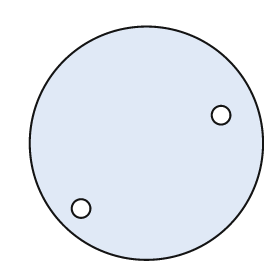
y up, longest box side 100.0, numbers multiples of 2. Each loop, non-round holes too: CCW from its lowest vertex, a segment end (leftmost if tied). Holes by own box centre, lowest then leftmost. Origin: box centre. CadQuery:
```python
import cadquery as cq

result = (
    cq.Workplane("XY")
    .moveTo(0.0, 0.0)
    .circle(50.0)
    .moveTo(-28.0, -28.0)
    .circle(4.0)
    .moveTo(32.0, 12.0)
    .circle(4.0)
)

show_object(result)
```